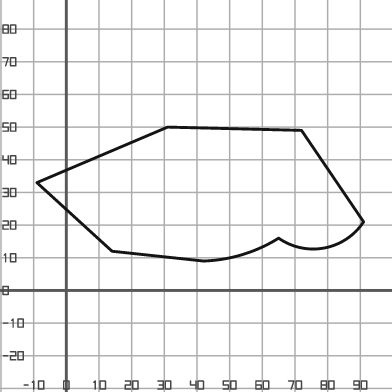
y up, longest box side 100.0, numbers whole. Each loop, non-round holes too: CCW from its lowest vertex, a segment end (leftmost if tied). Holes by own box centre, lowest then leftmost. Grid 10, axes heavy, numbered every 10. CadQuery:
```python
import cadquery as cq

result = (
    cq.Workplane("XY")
    .moveTo(42.0, 9.0)
    .threePointArc((54.0, 11.0), (65.0, 16.0))
    .threePointArc((79.0, 13.0), (91.0, 21.0))
    .lineTo(72.0, 49.0)
    .lineTo(31.0, 50.0)
    .lineTo(-9.0, 33.0)
    .lineTo(14.0, 12.0)
    .close()
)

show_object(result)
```